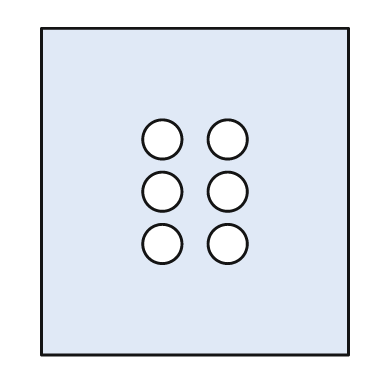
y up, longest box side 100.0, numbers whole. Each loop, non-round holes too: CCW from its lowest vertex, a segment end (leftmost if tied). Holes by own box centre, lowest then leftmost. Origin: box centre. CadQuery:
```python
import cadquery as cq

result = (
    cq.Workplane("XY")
    .moveTo(-47.0, -50.0)
    .lineTo(47.0, -50.0)
    .lineTo(47.0, 50.0)
    .lineTo(-47.0, 50.0)
    .close()
    .moveTo(-10.0, -16.0)
    .circle(6.0)
    .moveTo(10.0, -16.0)
    .circle(6.0)
    .moveTo(-10.0, 0.0)
    .circle(6.0)
    .moveTo(10.0, 0.0)
    .circle(6.0)
    .moveTo(-10.0, 16.0)
    .circle(6.0)
    .moveTo(10.0, 16.0)
    .circle(6.0)
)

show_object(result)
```